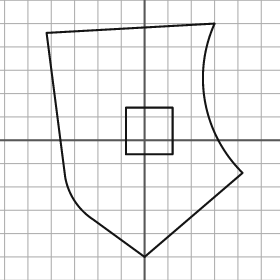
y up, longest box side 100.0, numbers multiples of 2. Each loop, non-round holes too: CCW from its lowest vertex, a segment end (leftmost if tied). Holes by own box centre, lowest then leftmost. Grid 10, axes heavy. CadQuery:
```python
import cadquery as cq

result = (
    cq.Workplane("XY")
    .moveTo(0.0, -50.0)
    .lineTo(42.0, -14.0)
    .threePointArc((26.0, 16.0), (30.0, 50.0))
    .lineTo(-42.0, 46.0)
    .lineTo(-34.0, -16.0)
    .threePointArc((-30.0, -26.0), (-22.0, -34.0))
    .close()
    .moveTo(-8.0, -6.0)
    .lineTo(12.0, -6.0)
    .lineTo(12.0, 14.0)
    .lineTo(-8.0, 14.0)
    .close()
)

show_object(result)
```